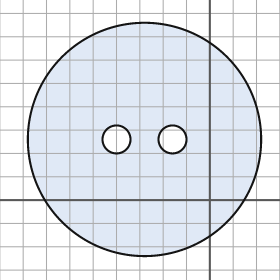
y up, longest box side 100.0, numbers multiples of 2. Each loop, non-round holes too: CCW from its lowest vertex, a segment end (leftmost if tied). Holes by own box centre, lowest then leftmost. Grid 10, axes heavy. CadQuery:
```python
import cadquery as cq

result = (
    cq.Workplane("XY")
    .moveTo(-28.0, 26.0)
    .circle(50.0)
    .moveTo(-40.0, 26.0)
    .circle(6.0)
    .moveTo(-16.0, 26.0)
    .circle(6.0)
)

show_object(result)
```